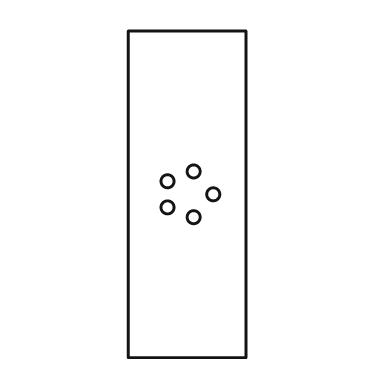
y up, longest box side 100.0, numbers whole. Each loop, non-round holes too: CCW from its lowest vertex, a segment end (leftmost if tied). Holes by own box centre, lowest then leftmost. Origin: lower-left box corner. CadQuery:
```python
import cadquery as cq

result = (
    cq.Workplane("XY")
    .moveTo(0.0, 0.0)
    .lineTo(36.0, 0.0)
    .lineTo(36.0, 100.0)
    .lineTo(0.0, 100.0)
    .close()
    .moveTo(20.0, 43.0)
    .circle(2.0)
    .moveTo(12.0, 46.0)
    .circle(2.0)
    .moveTo(26.0, 50.0)
    .circle(2.0)
    .moveTo(12.0, 54.0)
    .circle(2.0)
    .moveTo(20.0, 57.0)
    .circle(2.0)
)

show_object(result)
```